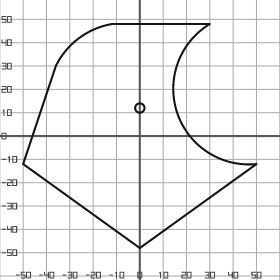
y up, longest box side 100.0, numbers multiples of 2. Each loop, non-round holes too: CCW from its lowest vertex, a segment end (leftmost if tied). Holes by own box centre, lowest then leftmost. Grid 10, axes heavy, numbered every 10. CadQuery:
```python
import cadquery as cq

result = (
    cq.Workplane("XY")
    .moveTo(0.0, -48.0)
    .lineTo(50.0, -12.0)
    .threePointArc((16.0, 10.0), (30.0, 48.0))
    .lineTo(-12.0, 48.0)
    .threePointArc((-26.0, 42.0), (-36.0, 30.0))
    .lineTo(-50.0, -12.0)
    .close()
    .moveTo(0.0, 12.0)
    .circle(2.0)
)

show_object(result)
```